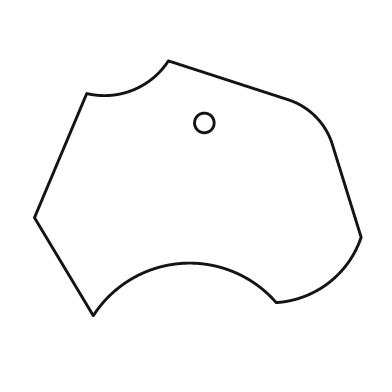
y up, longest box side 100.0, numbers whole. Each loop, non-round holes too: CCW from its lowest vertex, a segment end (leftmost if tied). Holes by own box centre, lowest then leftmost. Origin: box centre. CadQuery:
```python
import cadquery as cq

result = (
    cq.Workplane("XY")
    .moveTo(-32.0, -39.0)
    .threePointArc((-5.0, -23.0), (24.0, -35.0))
    .threePointArc((40.0, -29.0), (50.0, -15.0))
    .lineTo(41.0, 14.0)
    .threePointArc((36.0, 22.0), (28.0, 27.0))
    .lineTo(-9.0, 39.0)
    .threePointArc((-20.0, 30.0), (-34.0, 29.0))
    .lineTo(-50.0, -9.0)
    .close()
    .moveTo(2.0, 20.0)
    .circle(3.0)
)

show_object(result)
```